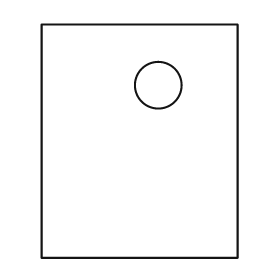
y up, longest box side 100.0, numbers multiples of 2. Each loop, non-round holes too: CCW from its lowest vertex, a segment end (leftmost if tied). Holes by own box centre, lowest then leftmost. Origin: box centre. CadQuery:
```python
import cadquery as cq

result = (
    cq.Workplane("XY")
    .moveTo(-42.0, -50.0)
    .lineTo(42.0, -50.0)
    .lineTo(42.0, 50.0)
    .lineTo(-42.0, 50.0)
    .close()
    .moveTo(8.0, 24.0)
    .circle(10.0)
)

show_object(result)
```